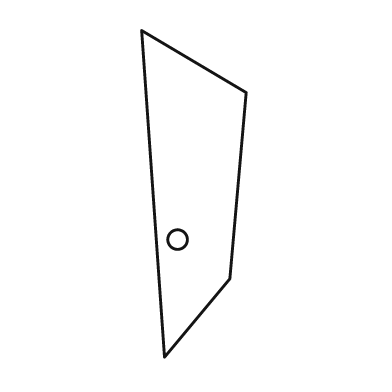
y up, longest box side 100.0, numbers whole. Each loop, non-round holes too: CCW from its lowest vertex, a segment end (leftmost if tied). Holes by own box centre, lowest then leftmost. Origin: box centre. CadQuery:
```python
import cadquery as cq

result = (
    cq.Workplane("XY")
    .moveTo(-9.0, -50.0)
    .lineTo(11.0, -26.0)
    .lineTo(16.0, 31.0)
    .lineTo(-16.0, 50.0)
    .close()
    .moveTo(-5.0, -14.0)
    .circle(3.0)
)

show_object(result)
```